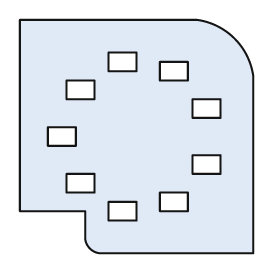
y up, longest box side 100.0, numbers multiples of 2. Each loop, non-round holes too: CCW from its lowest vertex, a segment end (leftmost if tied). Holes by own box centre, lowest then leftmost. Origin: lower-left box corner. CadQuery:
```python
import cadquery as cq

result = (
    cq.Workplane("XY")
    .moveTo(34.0, 0.0)
    .lineTo(100.0, 0.0)
    .lineTo(100.0, 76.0)
    .threePointArc((92.0, 92.0), (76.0, 100.0))
    .lineTo(0.0, 100.0)
    .lineTo(0.0, 18.0)
    .lineTo(28.0, 18.0)
    .lineTo(28.0, 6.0)
    .threePointArc((30.0, 2.0), (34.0, 0.0))
    .close()
    .moveTo(38.0, 14.0)
    .lineTo(50.0, 14.0)
    .lineTo(50.0, 22.0)
    .lineTo(38.0, 22.0)
    .close()
    .moveTo(60.0, 18.0)
    .lineTo(72.0, 18.0)
    .lineTo(72.0, 26.0)
    .lineTo(60.0, 26.0)
    .close()
    .moveTo(20.0, 26.0)
    .lineTo(32.0, 26.0)
    .lineTo(32.0, 34.0)
    .lineTo(20.0, 34.0)
    .close()
    .moveTo(74.0, 34.0)
    .lineTo(86.0, 34.0)
    .lineTo(86.0, 42.0)
    .lineTo(74.0, 42.0)
    .close()
    .moveTo(12.0, 46.0)
    .lineTo(24.0, 46.0)
    .lineTo(24.0, 54.0)
    .lineTo(12.0, 54.0)
    .close()
    .moveTo(74.0, 58.0)
    .lineTo(86.0, 58.0)
    .lineTo(86.0, 66.0)
    .lineTo(74.0, 66.0)
    .close()
    .moveTo(20.0, 66.0)
    .lineTo(32.0, 66.0)
    .lineTo(32.0, 74.0)
    .lineTo(20.0, 74.0)
    .close()
    .moveTo(60.0, 74.0)
    .lineTo(72.0, 74.0)
    .lineTo(72.0, 82.0)
    .lineTo(60.0, 82.0)
    .close()
    .moveTo(38.0, 78.0)
    .lineTo(50.0, 78.0)
    .lineTo(50.0, 86.0)
    .lineTo(38.0, 86.0)
    .close()
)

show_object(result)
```